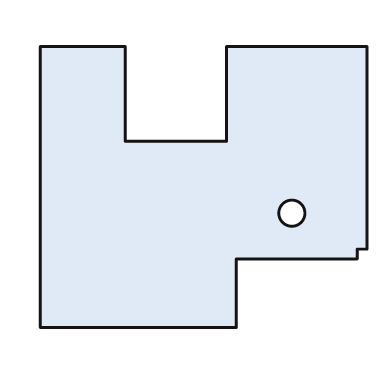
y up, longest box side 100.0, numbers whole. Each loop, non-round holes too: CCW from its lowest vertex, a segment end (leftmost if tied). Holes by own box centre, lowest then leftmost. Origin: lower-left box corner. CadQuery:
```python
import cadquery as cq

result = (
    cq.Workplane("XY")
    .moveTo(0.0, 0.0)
    .lineTo(60.0, 0.0)
    .lineTo(60.0, 21.0)
    .lineTo(97.0, 21.0)
    .lineTo(97.0, 24.0)
    .lineTo(100.0, 24.0)
    .lineTo(100.0, 86.0)
    .lineTo(57.0, 86.0)
    .lineTo(57.0, 57.0)
    .lineTo(26.0, 57.0)
    .lineTo(26.0, 86.0)
    .lineTo(0.0, 86.0)
    .close()
    .moveTo(77.0, 35.0)
    .circle(4.0)
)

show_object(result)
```